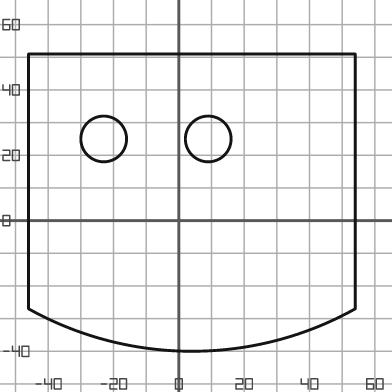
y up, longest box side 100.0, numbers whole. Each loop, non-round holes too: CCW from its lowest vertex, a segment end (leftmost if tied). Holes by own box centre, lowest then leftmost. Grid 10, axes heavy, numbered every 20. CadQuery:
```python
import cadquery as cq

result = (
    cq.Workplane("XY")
    .moveTo(-46.0, -27.0)
    .threePointArc((4.0, -40.0), (54.0, -27.0))
    .lineTo(54.0, 51.0)
    .lineTo(-46.0, 51.0)
    .close()
    .moveTo(-23.0, 25.0)
    .circle(7.0)
    .moveTo(9.0, 25.0)
    .circle(7.0)
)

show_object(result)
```